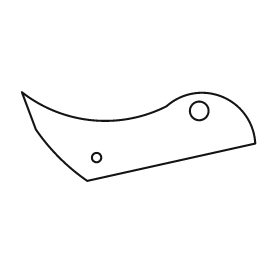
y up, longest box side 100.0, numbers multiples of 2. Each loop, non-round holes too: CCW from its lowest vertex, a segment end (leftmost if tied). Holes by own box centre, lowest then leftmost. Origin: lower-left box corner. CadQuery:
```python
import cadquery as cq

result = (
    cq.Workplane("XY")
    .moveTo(28.0, 0.0)
    .lineTo(100.0, 16.0)
    .threePointArc((86.0, 36.0), (62.0, 32.0))
    .threePointArc((30.0, 26.0), (0.0, 38.0))
    .lineTo(6.0, 22.0)
    .threePointArc((16.0, 10.0), (28.0, 0.0))
    .close()
    .moveTo(32.0, 10.0)
    .circle(2.0)
    .moveTo(76.0, 30.0)
    .circle(4.0)
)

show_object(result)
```